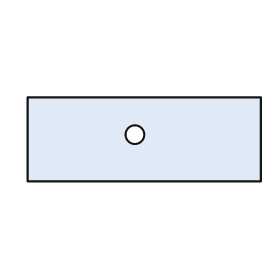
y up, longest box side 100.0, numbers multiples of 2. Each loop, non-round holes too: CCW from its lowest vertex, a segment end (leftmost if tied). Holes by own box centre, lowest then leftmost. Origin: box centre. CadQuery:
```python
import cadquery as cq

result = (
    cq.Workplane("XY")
    .moveTo(-50.0, -18.0)
    .lineTo(50.0, -18.0)
    .lineTo(50.0, 18.0)
    .lineTo(-50.0, 18.0)
    .close()
    .moveTo(-4.0, 2.0)
    .circle(4.0)
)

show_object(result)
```